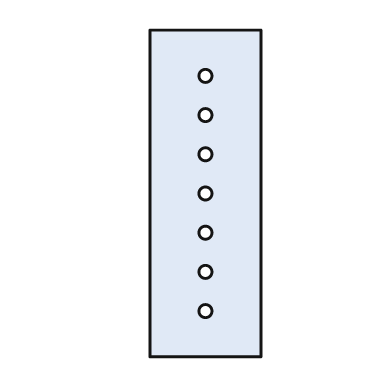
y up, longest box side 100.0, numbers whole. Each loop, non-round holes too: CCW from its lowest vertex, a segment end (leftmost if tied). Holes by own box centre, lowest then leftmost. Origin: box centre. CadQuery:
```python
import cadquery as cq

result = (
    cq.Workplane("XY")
    .moveTo(-17.0, -50.0)
    .lineTo(17.0, -50.0)
    .lineTo(17.0, 50.0)
    .lineTo(-17.0, 50.0)
    .close()
    .moveTo(0.0, -36.0)
    .circle(2.0)
    .moveTo(0.0, -24.0)
    .circle(2.0)
    .moveTo(0.0, -12.0)
    .circle(2.0)
    .moveTo(0.0, 0.0)
    .circle(2.0)
    .moveTo(0.0, 12.0)
    .circle(2.0)
    .moveTo(0.0, 24.0)
    .circle(2.0)
    .moveTo(0.0, 36.0)
    .circle(2.0)
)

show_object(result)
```